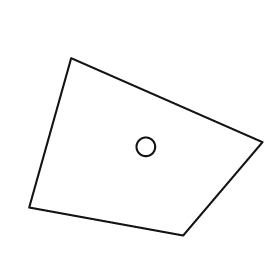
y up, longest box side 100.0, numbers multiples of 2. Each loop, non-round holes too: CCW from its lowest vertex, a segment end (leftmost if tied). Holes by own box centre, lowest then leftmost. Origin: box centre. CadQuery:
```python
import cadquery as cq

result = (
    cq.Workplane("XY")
    .moveTo(16.0, -38.0)
    .lineTo(50.0, 2.0)
    .lineTo(-32.0, 38.0)
    .lineTo(-50.0, -26.0)
    .close()
    .moveTo(0.0, 0.0)
    .circle(4.0)
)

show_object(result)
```